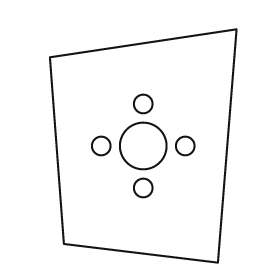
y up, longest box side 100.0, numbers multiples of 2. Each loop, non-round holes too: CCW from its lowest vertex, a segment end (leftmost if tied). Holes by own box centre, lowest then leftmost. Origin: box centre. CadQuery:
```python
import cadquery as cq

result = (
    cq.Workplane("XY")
    .moveTo(32.0, -50.0)
    .lineTo(40.0, 50.0)
    .lineTo(-40.0, 38.0)
    .lineTo(-34.0, -42.0)
    .close()
    .moveTo(0.0, -18.0)
    .circle(4.0)
    .moveTo(-18.0, 0.0)
    .circle(4.0)
    .moveTo(0.0, 0.0)
    .circle(10.0)
    .moveTo(18.0, 0.0)
    .circle(4.0)
    .moveTo(0.0, 18.0)
    .circle(4.0)
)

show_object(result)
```